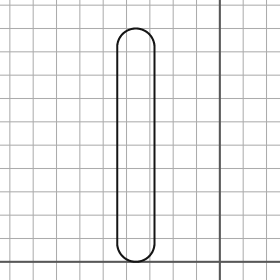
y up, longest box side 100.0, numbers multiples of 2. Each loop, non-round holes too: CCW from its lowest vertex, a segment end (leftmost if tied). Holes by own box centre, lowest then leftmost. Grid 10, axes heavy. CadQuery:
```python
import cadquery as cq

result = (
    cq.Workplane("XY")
    .moveTo(-44.0, 8.0)
    .threePointArc((-36.0, 0.0), (-28.0, 8.0))
    .lineTo(-28.0, 92.0)
    .threePointArc((-36.0, 100.0), (-44.0, 92.0))
    .close()
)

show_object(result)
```